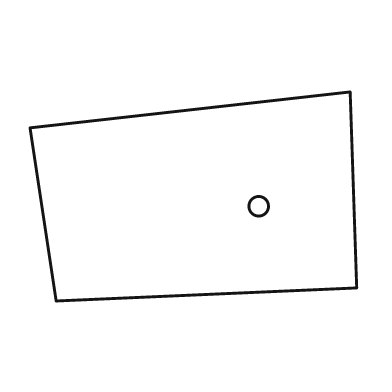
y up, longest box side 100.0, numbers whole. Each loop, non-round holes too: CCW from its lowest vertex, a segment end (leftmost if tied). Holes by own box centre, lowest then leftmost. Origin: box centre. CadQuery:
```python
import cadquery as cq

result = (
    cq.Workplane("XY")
    .moveTo(-42.0, -32.0)
    .lineTo(50.0, -28.0)
    .lineTo(48.0, 32.0)
    .lineTo(-50.0, 21.0)
    .close()
    .moveTo(20.0, -3.0)
    .circle(3.0)
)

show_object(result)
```